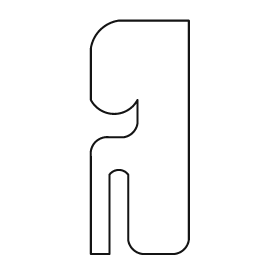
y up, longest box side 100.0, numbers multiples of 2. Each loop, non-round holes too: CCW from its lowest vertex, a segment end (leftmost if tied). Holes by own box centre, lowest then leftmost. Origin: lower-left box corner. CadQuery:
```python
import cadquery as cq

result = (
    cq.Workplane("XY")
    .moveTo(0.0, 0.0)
    .lineTo(8.0, 0.0)
    .lineTo(8.0, 34.0)
    .threePointArc((12.0, 36.0), (16.0, 34.0))
    .lineTo(16.0, 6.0)
    .threePointArc((18.0, 2.0), (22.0, 0.0))
    .lineTo(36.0, 0.0)
    .threePointArc((40.0, 2.0), (42.0, 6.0))
    .lineTo(42.0, 100.0)
    .lineTo(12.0, 100.0)
    .threePointArc((4.0, 96.0), (0.0, 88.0))
    .lineTo(0.0, 66.0)
    .threePointArc((10.0, 60.0), (20.0, 66.0))
    .lineTo(20.0, 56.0)
    .threePointArc((18.0, 52.0), (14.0, 50.0))
    .lineTo(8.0, 50.0)
    .threePointArc((2.0, 48.0), (0.0, 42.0))
    .close()
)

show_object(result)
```